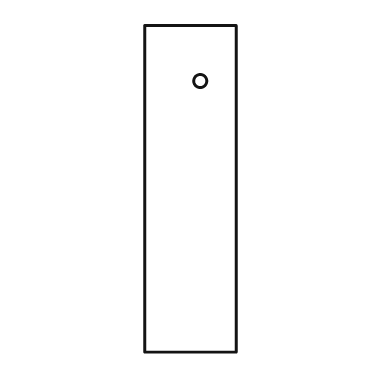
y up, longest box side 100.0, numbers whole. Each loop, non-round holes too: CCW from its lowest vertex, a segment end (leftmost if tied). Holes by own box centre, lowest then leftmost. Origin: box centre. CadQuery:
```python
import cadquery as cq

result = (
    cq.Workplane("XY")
    .moveTo(-14.0, -50.0)
    .lineTo(14.0, -50.0)
    .lineTo(14.0, 50.0)
    .lineTo(-14.0, 50.0)
    .close()
    .moveTo(3.0, 33.0)
    .circle(2.0)
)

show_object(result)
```